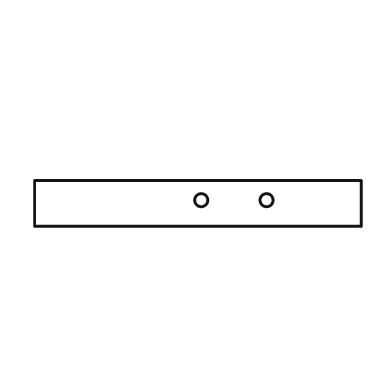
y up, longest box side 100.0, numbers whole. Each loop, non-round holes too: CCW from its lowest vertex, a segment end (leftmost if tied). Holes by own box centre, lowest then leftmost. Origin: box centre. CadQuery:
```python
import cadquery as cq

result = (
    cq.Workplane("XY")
    .moveTo(-50.0, -7.0)
    .lineTo(50.0, -7.0)
    .lineTo(50.0, 7.0)
    .lineTo(-50.0, 7.0)
    .close()
    .moveTo(1.0, 1.0)
    .circle(2.0)
    .moveTo(21.0, 1.0)
    .circle(2.0)
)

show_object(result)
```